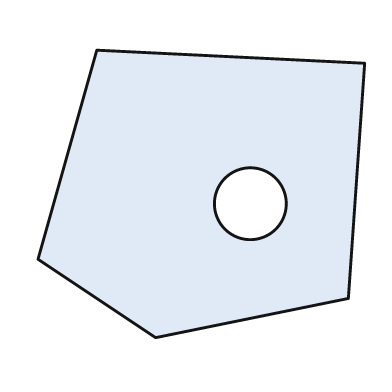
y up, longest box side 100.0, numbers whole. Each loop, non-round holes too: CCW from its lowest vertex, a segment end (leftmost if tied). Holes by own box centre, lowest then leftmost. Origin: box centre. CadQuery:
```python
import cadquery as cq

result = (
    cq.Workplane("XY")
    .moveTo(-14.0, -44.0)
    .lineTo(45.0, -32.0)
    .lineTo(50.0, 40.0)
    .lineTo(-32.0, 44.0)
    .lineTo(-50.0, -20.0)
    .close()
    .moveTo(15.0, -3.0)
    .circle(11.0)
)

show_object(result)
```